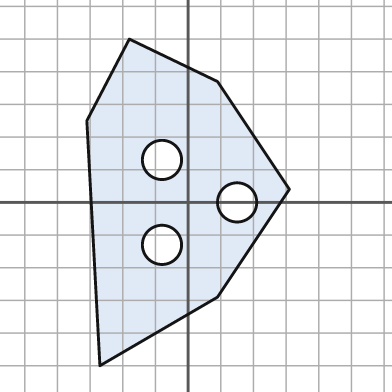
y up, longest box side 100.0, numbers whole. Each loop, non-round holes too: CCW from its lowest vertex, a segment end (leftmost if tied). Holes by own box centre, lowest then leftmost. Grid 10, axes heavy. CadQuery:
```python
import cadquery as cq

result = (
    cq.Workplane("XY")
    .moveTo(-27.0, -50.0)
    .lineTo(9.0, -29.0)
    .lineTo(31.0, 4.0)
    .lineTo(9.0, 37.0)
    .lineTo(-18.0, 50.0)
    .lineTo(-31.0, 25.0)
    .close()
    .moveTo(-8.0, -13.0)
    .circle(6.0)
    .moveTo(15.0, 0.0)
    .circle(6.0)
    .moveTo(-8.0, 13.0)
    .circle(6.0)
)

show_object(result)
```